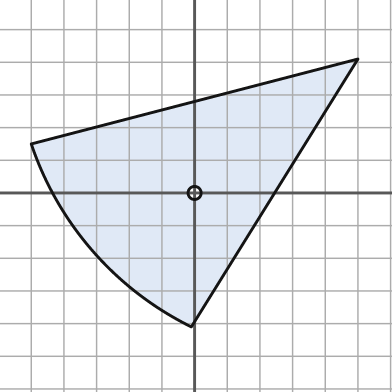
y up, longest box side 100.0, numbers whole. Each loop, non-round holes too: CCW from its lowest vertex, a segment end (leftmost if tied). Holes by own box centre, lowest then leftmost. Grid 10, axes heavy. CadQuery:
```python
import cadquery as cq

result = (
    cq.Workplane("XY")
    .moveTo(-1.0, -41.0)
    .lineTo(50.0, 41.0)
    .lineTo(-50.0, 15.0)
    .threePointArc((-31.0, -18.0), (-1.0, -41.0))
    .close()
    .moveTo(0.0, 0.0)
    .circle(2.0)
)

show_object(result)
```